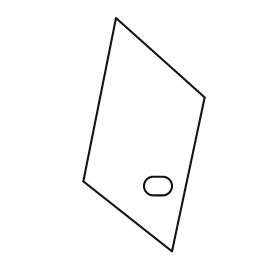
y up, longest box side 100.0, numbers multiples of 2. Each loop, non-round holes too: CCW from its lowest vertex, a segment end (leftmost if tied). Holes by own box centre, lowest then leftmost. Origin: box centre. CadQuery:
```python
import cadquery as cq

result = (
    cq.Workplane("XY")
    .moveTo(12.0, -50.0)
    .lineTo(26.0, 16.0)
    .lineTo(-12.0, 50.0)
    .lineTo(-26.0, -20.0)
    .close()
    .moveTo(4.0, -26.0)
    .lineTo(8.0, -26.0)
    .threePointArc((12.0, -22.0), (8.0, -18.0))
    .lineTo(4.0, -18.0)
    .threePointArc((0.0, -22.0), (4.0, -26.0))
    .close()
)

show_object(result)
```